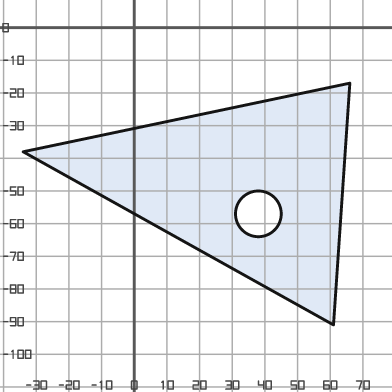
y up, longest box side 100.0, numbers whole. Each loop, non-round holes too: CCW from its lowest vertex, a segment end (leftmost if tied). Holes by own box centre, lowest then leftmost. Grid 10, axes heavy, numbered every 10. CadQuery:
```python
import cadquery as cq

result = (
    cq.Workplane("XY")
    .moveTo(61.0, -91.0)
    .lineTo(66.0, -17.0)
    .lineTo(-34.0, -38.0)
    .close()
    .moveTo(38.0, -57.0)
    .circle(7.0)
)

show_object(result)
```